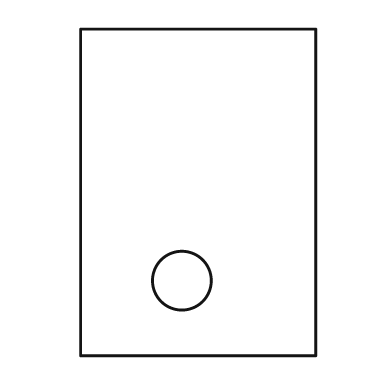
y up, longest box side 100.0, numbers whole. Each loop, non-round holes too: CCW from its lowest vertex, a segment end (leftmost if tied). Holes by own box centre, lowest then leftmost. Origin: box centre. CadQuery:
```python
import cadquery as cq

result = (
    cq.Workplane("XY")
    .moveTo(-36.0, -50.0)
    .lineTo(36.0, -50.0)
    .lineTo(36.0, 50.0)
    .lineTo(-36.0, 50.0)
    .close()
    .moveTo(-5.0, -27.0)
    .circle(9.0)
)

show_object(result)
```